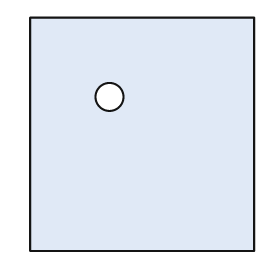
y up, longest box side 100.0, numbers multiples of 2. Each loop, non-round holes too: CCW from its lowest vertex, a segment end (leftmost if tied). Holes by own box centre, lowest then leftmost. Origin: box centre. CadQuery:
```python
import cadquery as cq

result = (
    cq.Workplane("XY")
    .moveTo(-48.0, -50.0)
    .lineTo(48.0, -50.0)
    .lineTo(48.0, 50.0)
    .lineTo(-48.0, 50.0)
    .close()
    .moveTo(-14.0, 16.0)
    .circle(6.0)
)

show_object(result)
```